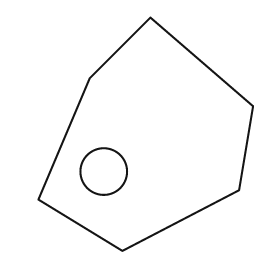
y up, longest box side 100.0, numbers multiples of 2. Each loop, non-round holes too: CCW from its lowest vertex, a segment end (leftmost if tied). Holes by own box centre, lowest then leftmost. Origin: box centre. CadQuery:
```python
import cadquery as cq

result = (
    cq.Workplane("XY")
    .moveTo(-10.0, -50.0)
    .lineTo(40.0, -24.0)
    .lineTo(46.0, 12.0)
    .lineTo(2.0, 50.0)
    .lineTo(-24.0, 24.0)
    .lineTo(-46.0, -28.0)
    .close()
    .moveTo(-18.0, -16.0)
    .circle(10.0)
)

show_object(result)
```